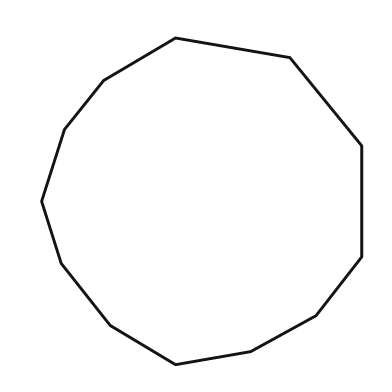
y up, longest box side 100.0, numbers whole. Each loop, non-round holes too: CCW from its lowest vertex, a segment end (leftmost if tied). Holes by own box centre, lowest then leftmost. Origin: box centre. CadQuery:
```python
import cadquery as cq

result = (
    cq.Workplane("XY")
    .moveTo(-8.0, -50.0)
    .lineTo(15.0, -46.0)
    .lineTo(35.0, -35.0)
    .lineTo(49.0, -17.0)
    .lineTo(49.0, 17.0)
    .lineTo(27.0, 44.0)
    .lineTo(-8.0, 50.0)
    .lineTo(-30.0, 37.0)
    .lineTo(-42.0, 22.0)
    .lineTo(-49.0, 0.0)
    .lineTo(-43.0, -19.0)
    .lineTo(-28.0, -38.0)
    .close()
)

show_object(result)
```